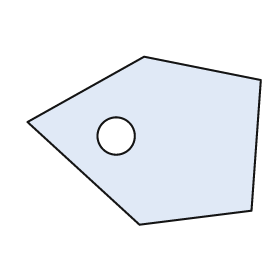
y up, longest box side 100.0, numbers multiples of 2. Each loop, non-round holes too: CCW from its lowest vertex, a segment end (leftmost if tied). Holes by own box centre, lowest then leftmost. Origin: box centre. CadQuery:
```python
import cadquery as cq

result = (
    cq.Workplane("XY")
    .moveTo(-2.0, -36.0)
    .lineTo(46.0, -30.0)
    .lineTo(50.0, 26.0)
    .lineTo(0.0, 36.0)
    .lineTo(-50.0, 8.0)
    .close()
    .moveTo(-12.0, 2.0)
    .circle(8.0)
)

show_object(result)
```